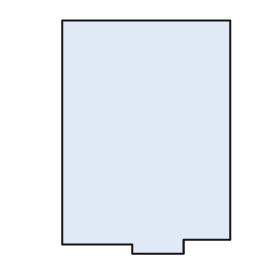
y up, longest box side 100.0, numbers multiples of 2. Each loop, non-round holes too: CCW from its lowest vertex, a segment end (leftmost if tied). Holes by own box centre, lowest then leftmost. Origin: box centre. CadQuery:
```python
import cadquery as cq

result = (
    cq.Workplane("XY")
    .moveTo(-6.0, -50.0)
    .lineTo(16.0, -50.0)
    .lineTo(16.0, -44.0)
    .lineTo(36.0, -44.0)
    .lineTo(36.0, 50.0)
    .lineTo(-36.0, 50.0)
    .lineTo(-36.0, -46.0)
    .lineTo(-6.0, -46.0)
    .close()
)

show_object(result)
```